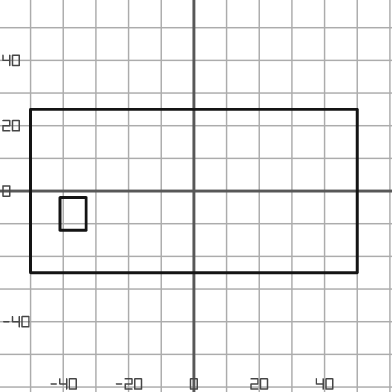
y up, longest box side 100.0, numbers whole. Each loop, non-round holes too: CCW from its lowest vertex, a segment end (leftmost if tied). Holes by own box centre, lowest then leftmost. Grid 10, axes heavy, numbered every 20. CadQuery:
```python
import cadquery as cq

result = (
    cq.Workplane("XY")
    .moveTo(-50.0, -25.0)
    .lineTo(50.0, -25.0)
    .lineTo(50.0, 25.0)
    .lineTo(-50.0, 25.0)
    .close()
    .moveTo(-41.0, -12.0)
    .lineTo(-33.0, -12.0)
    .lineTo(-33.0, -2.0)
    .lineTo(-41.0, -2.0)
    .close()
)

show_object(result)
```